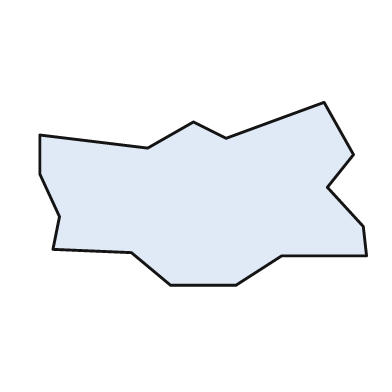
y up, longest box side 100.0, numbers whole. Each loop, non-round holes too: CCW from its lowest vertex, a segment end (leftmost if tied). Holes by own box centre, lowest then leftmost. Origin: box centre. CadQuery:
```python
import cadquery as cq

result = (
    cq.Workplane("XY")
    .moveTo(-10.0, -28.0)
    .lineTo(10.0, -28.0)
    .lineTo(24.0, -19.0)
    .lineTo(50.0, -19.0)
    .lineTo(49.0, -10.0)
    .lineTo(38.0, 2.0)
    .lineTo(46.0, 12.0)
    .lineTo(37.0, 28.0)
    .lineTo(7.0, 17.0)
    .lineTo(-3.0, 22.0)
    .lineTo(-17.0, 14.0)
    .lineTo(-50.0, 18.0)
    .lineTo(-50.0, 6.0)
    .lineTo(-44.0, -7.0)
    .lineTo(-46.0, -17.0)
    .lineTo(-22.0, -18.0)
    .close()
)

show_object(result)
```